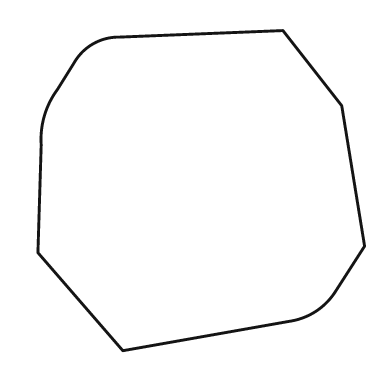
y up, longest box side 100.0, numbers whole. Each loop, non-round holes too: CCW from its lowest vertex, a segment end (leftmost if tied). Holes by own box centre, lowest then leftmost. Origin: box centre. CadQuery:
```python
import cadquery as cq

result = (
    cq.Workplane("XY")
    .moveTo(-24.0, -49.0)
    .lineTo(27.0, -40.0)
    .threePointArc((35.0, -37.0), (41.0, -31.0))
    .lineTo(50.0, -17.0)
    .lineTo(43.0, 26.0)
    .lineTo(25.0, 49.0)
    .lineTo(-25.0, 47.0)
    .threePointArc((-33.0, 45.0), (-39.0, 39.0))
    .lineTo(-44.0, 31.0)
    .threePointArc((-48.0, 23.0), (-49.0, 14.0))
    .lineTo(-50.0, -19.0)
    .close()
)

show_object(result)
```